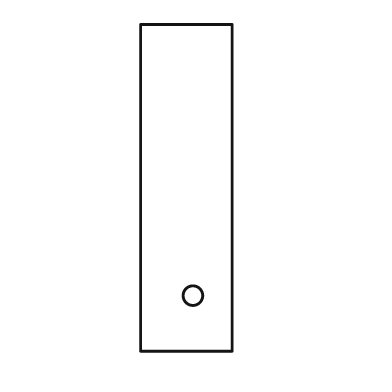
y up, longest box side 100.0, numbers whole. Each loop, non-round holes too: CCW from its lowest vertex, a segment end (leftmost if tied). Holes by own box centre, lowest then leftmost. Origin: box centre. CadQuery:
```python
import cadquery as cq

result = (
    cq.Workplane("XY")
    .moveTo(-14.0, -50.0)
    .lineTo(14.0, -50.0)
    .lineTo(14.0, 50.0)
    .lineTo(-14.0, 50.0)
    .close()
    .moveTo(2.0, -33.0)
    .circle(3.0)
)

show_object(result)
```